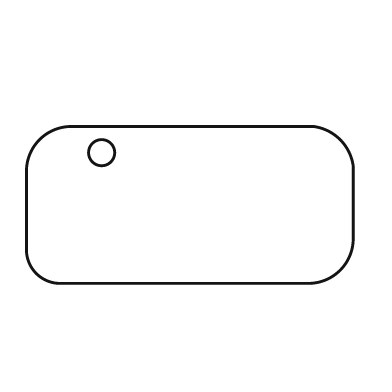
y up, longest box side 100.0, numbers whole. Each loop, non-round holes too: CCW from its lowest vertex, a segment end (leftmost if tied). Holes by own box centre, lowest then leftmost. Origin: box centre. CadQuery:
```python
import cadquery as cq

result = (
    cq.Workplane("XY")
    .moveTo(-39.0, -24.0)
    .lineTo(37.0, -24.0)
    .threePointArc((46.0, -20.0), (50.0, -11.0))
    .lineTo(50.0, 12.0)
    .threePointArc((46.0, 20.0), (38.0, 24.0))
    .lineTo(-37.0, 24.0)
    .threePointArc((-46.0, 20.0), (-50.0, 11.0))
    .lineTo(-50.0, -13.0)
    .threePointArc((-47.0, -21.0), (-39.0, -24.0))
    .close()
    .moveTo(-27.0, 16.0)
    .circle(4.0)
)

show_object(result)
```